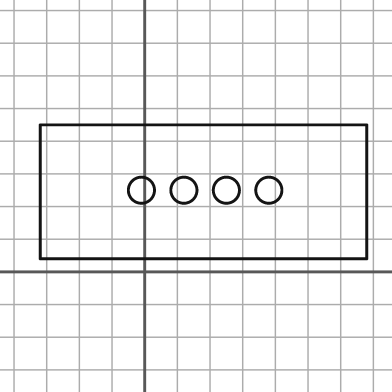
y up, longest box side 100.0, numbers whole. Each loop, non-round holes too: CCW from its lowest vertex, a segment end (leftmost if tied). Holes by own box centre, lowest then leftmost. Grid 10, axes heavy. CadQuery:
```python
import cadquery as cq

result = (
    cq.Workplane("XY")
    .moveTo(-32.0, 4.0)
    .lineTo(68.0, 4.0)
    .lineTo(68.0, 45.0)
    .lineTo(-32.0, 45.0)
    .close()
    .moveTo(-1.0, 25.0)
    .circle(4.0)
    .moveTo(12.0, 25.0)
    .circle(4.0)
    .moveTo(25.0, 25.0)
    .circle(4.0)
    .moveTo(38.0, 25.0)
    .circle(4.0)
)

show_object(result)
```